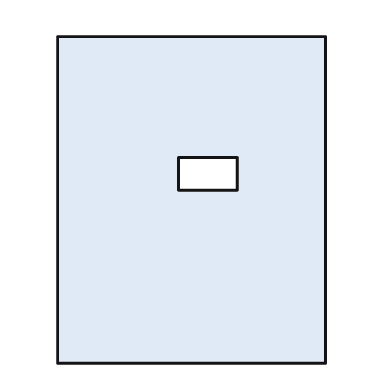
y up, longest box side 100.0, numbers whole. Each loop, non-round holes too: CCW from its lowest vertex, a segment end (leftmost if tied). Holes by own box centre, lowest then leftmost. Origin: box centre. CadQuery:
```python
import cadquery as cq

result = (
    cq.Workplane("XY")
    .moveTo(-41.0, -50.0)
    .lineTo(41.0, -50.0)
    .lineTo(41.0, 50.0)
    .lineTo(-41.0, 50.0)
    .close()
    .moveTo(-4.0, 3.0)
    .lineTo(14.0, 3.0)
    .lineTo(14.0, 13.0)
    .lineTo(-4.0, 13.0)
    .close()
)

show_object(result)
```